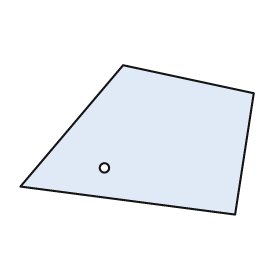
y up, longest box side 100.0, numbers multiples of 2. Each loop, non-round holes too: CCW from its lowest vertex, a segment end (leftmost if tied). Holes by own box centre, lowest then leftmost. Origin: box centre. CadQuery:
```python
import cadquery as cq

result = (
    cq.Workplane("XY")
    .moveTo(42.0, -32.0)
    .lineTo(50.0, 20.0)
    .lineTo(-6.0, 32.0)
    .lineTo(-50.0, -20.0)
    .close()
    .moveTo(-14.0, -12.0)
    .circle(2.0)
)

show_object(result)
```